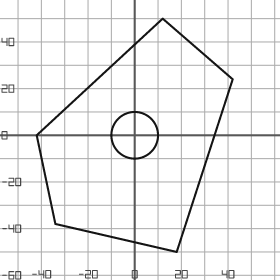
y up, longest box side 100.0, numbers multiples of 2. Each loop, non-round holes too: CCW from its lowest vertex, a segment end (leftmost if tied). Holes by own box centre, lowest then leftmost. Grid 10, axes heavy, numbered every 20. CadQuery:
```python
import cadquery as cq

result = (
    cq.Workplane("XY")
    .moveTo(18.0, -50.0)
    .lineTo(42.0, 24.0)
    .lineTo(12.0, 50.0)
    .lineTo(-42.0, 0.0)
    .lineTo(-34.0, -38.0)
    .close()
    .moveTo(0.0, 0.0)
    .circle(10.0)
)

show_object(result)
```